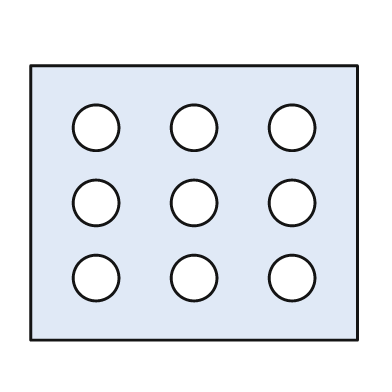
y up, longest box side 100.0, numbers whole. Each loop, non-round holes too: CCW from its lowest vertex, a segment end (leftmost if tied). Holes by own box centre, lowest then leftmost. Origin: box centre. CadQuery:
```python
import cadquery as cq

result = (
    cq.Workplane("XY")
    .moveTo(-50.0, -42.0)
    .lineTo(50.0, -42.0)
    .lineTo(50.0, 42.0)
    .lineTo(-50.0, 42.0)
    .close()
    .moveTo(-30.0, -23.0)
    .circle(7.0)
    .moveTo(0.0, -23.0)
    .circle(7.0)
    .moveTo(30.0, -23.0)
    .circle(7.0)
    .moveTo(-30.0, 0.0)
    .circle(7.0)
    .moveTo(0.0, 0.0)
    .circle(7.0)
    .moveTo(30.0, 0.0)
    .circle(7.0)
    .moveTo(-30.0, 23.0)
    .circle(7.0)
    .moveTo(0.0, 23.0)
    .circle(7.0)
    .moveTo(30.0, 23.0)
    .circle(7.0)
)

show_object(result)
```